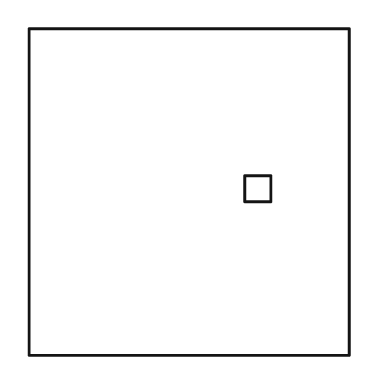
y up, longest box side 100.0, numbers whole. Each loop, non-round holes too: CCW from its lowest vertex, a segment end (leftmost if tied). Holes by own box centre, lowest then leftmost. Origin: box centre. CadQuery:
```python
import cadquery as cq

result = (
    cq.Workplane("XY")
    .moveTo(-49.0, -50.0)
    .lineTo(49.0, -50.0)
    .lineTo(49.0, 50.0)
    .lineTo(-49.0, 50.0)
    .close()
    .moveTo(17.0, -3.0)
    .lineTo(25.0, -3.0)
    .lineTo(25.0, 5.0)
    .lineTo(17.0, 5.0)
    .close()
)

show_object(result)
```